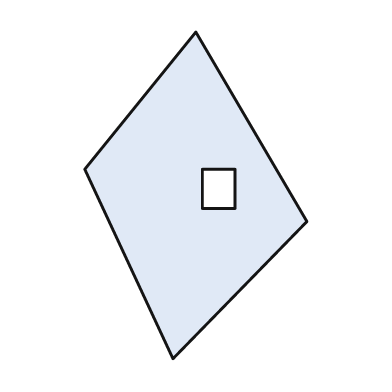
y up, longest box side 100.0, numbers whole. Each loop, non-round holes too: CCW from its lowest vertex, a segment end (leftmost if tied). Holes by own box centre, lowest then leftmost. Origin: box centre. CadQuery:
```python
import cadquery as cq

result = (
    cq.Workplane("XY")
    .moveTo(-7.0, -50.0)
    .lineTo(34.0, -8.0)
    .lineTo(0.0, 50.0)
    .lineTo(-34.0, 8.0)
    .close()
    .moveTo(2.0, -4.0)
    .lineTo(12.0, -4.0)
    .lineTo(12.0, 8.0)
    .lineTo(2.0, 8.0)
    .close()
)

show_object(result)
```